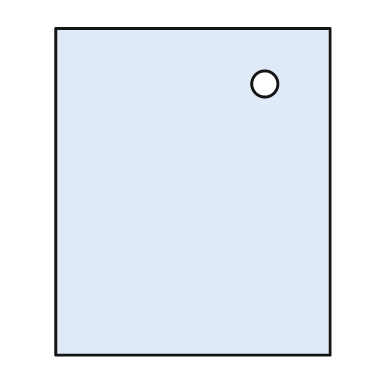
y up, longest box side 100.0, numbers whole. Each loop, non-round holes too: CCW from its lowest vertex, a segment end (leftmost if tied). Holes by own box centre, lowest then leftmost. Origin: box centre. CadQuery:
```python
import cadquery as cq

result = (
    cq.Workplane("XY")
    .moveTo(-42.0, -50.0)
    .lineTo(42.0, -50.0)
    .lineTo(42.0, 50.0)
    .lineTo(-42.0, 50.0)
    .close()
    .moveTo(22.0, 33.0)
    .circle(4.0)
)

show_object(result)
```